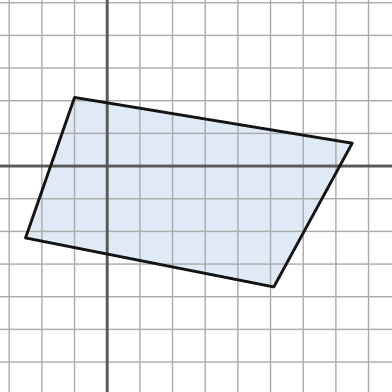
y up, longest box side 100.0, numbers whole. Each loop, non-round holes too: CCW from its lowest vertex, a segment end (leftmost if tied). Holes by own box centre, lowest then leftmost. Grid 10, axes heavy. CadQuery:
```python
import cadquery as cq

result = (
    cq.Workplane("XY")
    .moveTo(51.0, -37.0)
    .lineTo(75.0, 7.0)
    .lineTo(-10.0, 21.0)
    .lineTo(-25.0, -22.0)
    .close()
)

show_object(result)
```